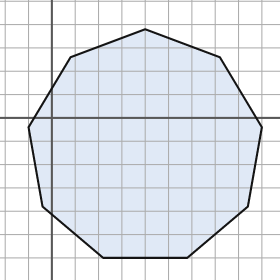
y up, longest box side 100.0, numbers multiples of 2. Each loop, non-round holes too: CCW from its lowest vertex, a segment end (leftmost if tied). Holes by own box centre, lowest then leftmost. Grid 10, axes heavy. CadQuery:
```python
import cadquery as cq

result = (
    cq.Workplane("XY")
    .moveTo(22.0, -60.0)
    .lineTo(58.0, -60.0)
    .lineTo(84.0, -38.0)
    .lineTo(90.0, -4.0)
    .lineTo(72.0, 26.0)
    .lineTo(40.0, 38.0)
    .lineTo(8.0, 26.0)
    .lineTo(-10.0, -4.0)
    .lineTo(-4.0, -38.0)
    .close()
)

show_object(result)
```